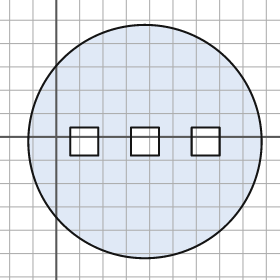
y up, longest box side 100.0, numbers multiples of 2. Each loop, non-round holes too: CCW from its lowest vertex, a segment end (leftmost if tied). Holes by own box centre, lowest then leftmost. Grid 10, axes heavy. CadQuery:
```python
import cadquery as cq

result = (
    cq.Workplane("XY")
    .moveTo(38.0, -2.0)
    .circle(50.0)
    .moveTo(6.0, -8.0)
    .lineTo(18.0, -8.0)
    .lineTo(18.0, 4.0)
    .lineTo(6.0, 4.0)
    .close()
    .moveTo(32.0, -8.0)
    .lineTo(44.0, -8.0)
    .lineTo(44.0, 4.0)
    .lineTo(32.0, 4.0)
    .close()
    .moveTo(58.0, -8.0)
    .lineTo(70.0, -8.0)
    .lineTo(70.0, 4.0)
    .lineTo(58.0, 4.0)
    .close()
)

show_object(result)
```